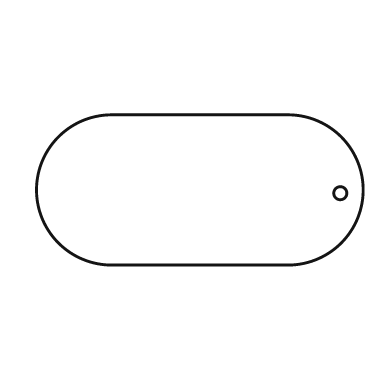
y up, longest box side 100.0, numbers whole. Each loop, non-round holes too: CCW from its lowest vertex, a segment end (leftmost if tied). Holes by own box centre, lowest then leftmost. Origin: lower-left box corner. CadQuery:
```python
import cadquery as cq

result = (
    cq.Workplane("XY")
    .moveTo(23.0, 0.0)
    .lineTo(77.0, 0.0)
    .threePointArc((100.0, 23.0), (77.0, 46.0))
    .lineTo(23.0, 46.0)
    .threePointArc((0.0, 23.0), (23.0, 0.0))
    .close()
    .moveTo(93.0, 22.0)
    .circle(2.0)
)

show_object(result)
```